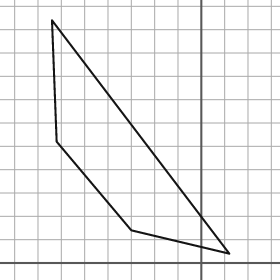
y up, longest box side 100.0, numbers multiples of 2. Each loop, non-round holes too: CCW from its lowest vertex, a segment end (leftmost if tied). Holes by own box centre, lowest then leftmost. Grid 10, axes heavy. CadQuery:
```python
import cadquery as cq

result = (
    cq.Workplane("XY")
    .moveTo(12.0, 4.0)
    .lineTo(-64.0, 104.0)
    .lineTo(-62.0, 52.0)
    .lineTo(-30.0, 14.0)
    .close()
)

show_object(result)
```